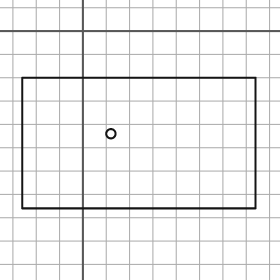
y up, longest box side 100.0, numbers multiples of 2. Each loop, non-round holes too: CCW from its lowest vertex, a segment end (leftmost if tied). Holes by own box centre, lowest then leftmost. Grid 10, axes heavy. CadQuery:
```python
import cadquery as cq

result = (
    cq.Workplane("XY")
    .moveTo(-26.0, -76.0)
    .lineTo(74.0, -76.0)
    .lineTo(74.0, -20.0)
    .lineTo(-26.0, -20.0)
    .close()
    .moveTo(12.0, -44.0)
    .circle(2.0)
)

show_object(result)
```